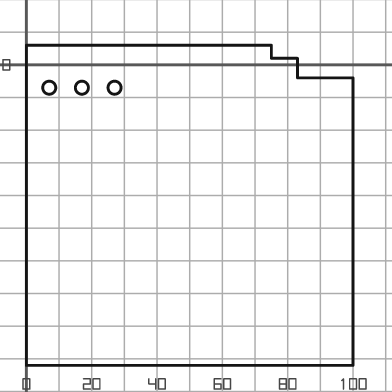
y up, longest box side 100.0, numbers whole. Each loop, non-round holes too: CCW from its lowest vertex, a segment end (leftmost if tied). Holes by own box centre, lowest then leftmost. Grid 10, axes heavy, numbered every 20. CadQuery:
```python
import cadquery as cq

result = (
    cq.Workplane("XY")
    .moveTo(0.0, -92.0)
    .lineTo(100.0, -92.0)
    .lineTo(100.0, -4.0)
    .lineTo(83.0, -4.0)
    .lineTo(83.0, 2.0)
    .lineTo(75.0, 2.0)
    .lineTo(75.0, 6.0)
    .lineTo(0.0, 6.0)
    .close()
    .moveTo(7.0, -7.0)
    .circle(2.0)
    .moveTo(17.0, -7.0)
    .circle(2.0)
    .moveTo(27.0, -7.0)
    .circle(2.0)
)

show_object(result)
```